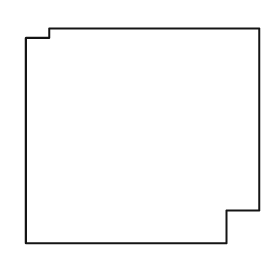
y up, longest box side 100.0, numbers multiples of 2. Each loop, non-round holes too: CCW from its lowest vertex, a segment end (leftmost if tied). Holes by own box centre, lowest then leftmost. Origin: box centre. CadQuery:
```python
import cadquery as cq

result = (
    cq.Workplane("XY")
    .moveTo(-50.0, -46.0)
    .lineTo(36.0, -46.0)
    .lineTo(36.0, -32.0)
    .lineTo(50.0, -32.0)
    .lineTo(50.0, 46.0)
    .lineTo(-40.0, 46.0)
    .lineTo(-40.0, 42.0)
    .lineTo(-50.0, 42.0)
    .close()
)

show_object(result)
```